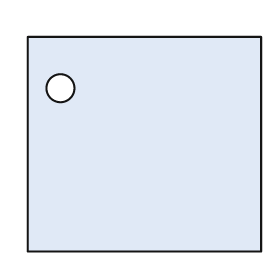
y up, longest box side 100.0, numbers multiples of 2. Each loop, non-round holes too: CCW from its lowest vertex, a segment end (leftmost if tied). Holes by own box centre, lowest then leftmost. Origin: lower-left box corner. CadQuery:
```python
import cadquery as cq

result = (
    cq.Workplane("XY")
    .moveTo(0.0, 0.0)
    .lineTo(100.0, 0.0)
    .lineTo(100.0, 92.0)
    .lineTo(0.0, 92.0)
    .close()
    .moveTo(14.0, 70.0)
    .circle(6.0)
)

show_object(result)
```